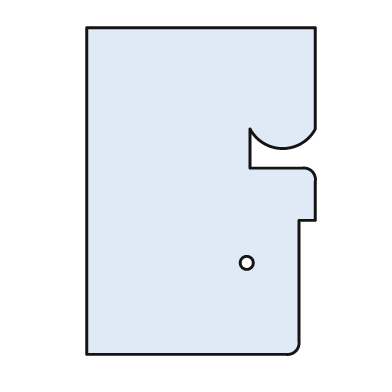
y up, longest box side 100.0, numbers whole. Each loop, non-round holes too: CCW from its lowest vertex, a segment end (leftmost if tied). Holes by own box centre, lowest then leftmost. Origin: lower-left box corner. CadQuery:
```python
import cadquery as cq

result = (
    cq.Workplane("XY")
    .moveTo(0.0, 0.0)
    .lineTo(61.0, 0.0)
    .threePointArc((64.0, 1.0), (65.0, 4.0))
    .lineTo(65.0, 41.0)
    .lineTo(70.0, 41.0)
    .lineTo(70.0, 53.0)
    .threePointArc((69.0, 56.0), (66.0, 57.0))
    .lineTo(50.0, 57.0)
    .lineTo(50.0, 69.0)
    .threePointArc((60.0, 63.0), (70.0, 69.0))
    .lineTo(70.0, 100.0)
    .lineTo(0.0, 100.0)
    .close()
    .moveTo(49.0, 28.0)
    .circle(2.0)
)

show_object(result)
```